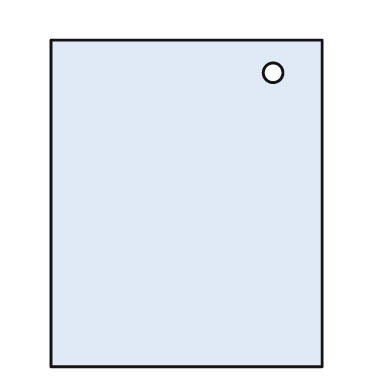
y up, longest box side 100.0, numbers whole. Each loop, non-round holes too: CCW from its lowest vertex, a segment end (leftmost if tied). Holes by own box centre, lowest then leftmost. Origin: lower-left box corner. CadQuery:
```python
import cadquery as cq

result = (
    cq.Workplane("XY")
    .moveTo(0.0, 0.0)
    .lineTo(83.0, 0.0)
    .lineTo(83.0, 100.0)
    .lineTo(0.0, 100.0)
    .close()
    .moveTo(68.0, 90.0)
    .circle(3.0)
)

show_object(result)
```